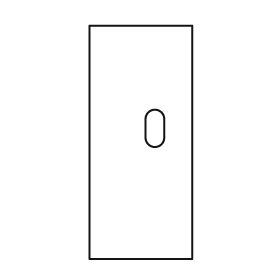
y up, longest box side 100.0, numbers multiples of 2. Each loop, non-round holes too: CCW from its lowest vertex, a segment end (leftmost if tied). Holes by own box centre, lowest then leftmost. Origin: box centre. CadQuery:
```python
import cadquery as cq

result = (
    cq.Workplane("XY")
    .moveTo(-22.0, -50.0)
    .lineTo(22.0, -50.0)
    .lineTo(22.0, 50.0)
    .lineTo(-22.0, 50.0)
    .close()
    .moveTo(2.0, 2.0)
    .threePointArc((6.0, -2.0), (10.0, 2.0))
    .lineTo(10.0, 10.0)
    .threePointArc((6.0, 14.0), (2.0, 10.0))
    .close()
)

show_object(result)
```